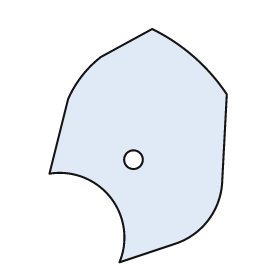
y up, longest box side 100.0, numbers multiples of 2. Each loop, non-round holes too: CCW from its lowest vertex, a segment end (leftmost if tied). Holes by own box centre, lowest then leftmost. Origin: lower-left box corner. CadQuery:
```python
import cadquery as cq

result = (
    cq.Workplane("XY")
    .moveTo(30.0, 0.0)
    .lineTo(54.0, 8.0)
    .threePointArc((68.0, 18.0), (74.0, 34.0))
    .lineTo(76.0, 72.0)
    .threePointArc((62.0, 88.0), (44.0, 100.0))
    .lineTo(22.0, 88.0)
    .threePointArc((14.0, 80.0), (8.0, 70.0))
    .lineTo(0.0, 38.0)
    .threePointArc((26.0, 28.0), (30.0, 0.0))
    .close()
    .moveTo(36.0, 44.0)
    .circle(4.0)
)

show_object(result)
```